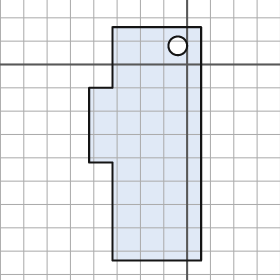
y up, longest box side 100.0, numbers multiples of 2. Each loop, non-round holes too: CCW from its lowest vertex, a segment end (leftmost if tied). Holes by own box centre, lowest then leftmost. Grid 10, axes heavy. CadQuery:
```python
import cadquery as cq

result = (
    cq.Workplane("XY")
    .moveTo(-32.0, -84.0)
    .lineTo(6.0, -84.0)
    .lineTo(6.0, 16.0)
    .lineTo(-32.0, 16.0)
    .lineTo(-32.0, -10.0)
    .lineTo(-42.0, -10.0)
    .lineTo(-42.0, -42.0)
    .lineTo(-32.0, -42.0)
    .close()
    .moveTo(-4.0, 8.0)
    .circle(4.0)
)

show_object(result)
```